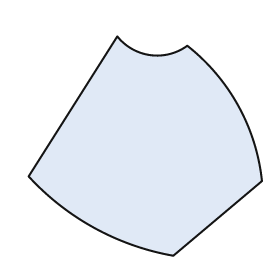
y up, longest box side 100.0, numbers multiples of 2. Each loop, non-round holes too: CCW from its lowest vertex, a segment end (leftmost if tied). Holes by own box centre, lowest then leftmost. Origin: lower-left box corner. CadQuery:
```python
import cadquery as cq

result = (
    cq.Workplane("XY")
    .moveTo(62.0, 0.0)
    .lineTo(100.0, 32.0)
    .threePointArc((90.0, 64.0), (68.0, 90.0))
    .threePointArc((52.0, 86.0), (38.0, 94.0))
    .lineTo(0.0, 34.0)
    .threePointArc((28.0, 12.0), (62.0, 0.0))
    .close()
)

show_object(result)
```